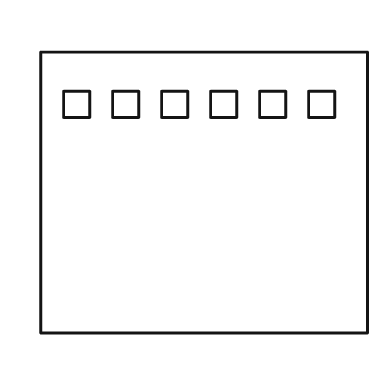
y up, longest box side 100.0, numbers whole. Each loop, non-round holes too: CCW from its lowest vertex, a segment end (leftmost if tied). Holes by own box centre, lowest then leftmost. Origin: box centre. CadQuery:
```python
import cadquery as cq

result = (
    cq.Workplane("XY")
    .moveTo(-50.0, -43.0)
    .lineTo(50.0, -43.0)
    .lineTo(50.0, 43.0)
    .lineTo(-50.0, 43.0)
    .close()
    .moveTo(-43.0, 23.0)
    .lineTo(-35.0, 23.0)
    .lineTo(-35.0, 31.0)
    .lineTo(-43.0, 31.0)
    .close()
    .moveTo(-28.0, 23.0)
    .lineTo(-20.0, 23.0)
    .lineTo(-20.0, 31.0)
    .lineTo(-28.0, 31.0)
    .close()
    .moveTo(-13.0, 23.0)
    .lineTo(-5.0, 23.0)
    .lineTo(-5.0, 31.0)
    .lineTo(-13.0, 31.0)
    .close()
    .moveTo(2.0, 23.0)
    .lineTo(10.0, 23.0)
    .lineTo(10.0, 31.0)
    .lineTo(2.0, 31.0)
    .close()
    .moveTo(17.0, 23.0)
    .lineTo(25.0, 23.0)
    .lineTo(25.0, 31.0)
    .lineTo(17.0, 31.0)
    .close()
    .moveTo(32.0, 23.0)
    .lineTo(40.0, 23.0)
    .lineTo(40.0, 31.0)
    .lineTo(32.0, 31.0)
    .close()
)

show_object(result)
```